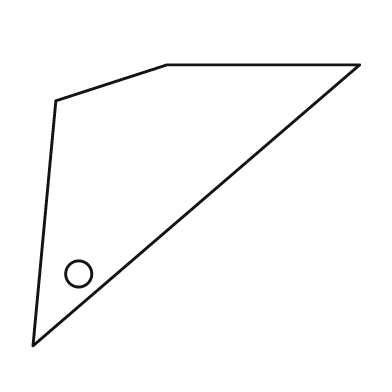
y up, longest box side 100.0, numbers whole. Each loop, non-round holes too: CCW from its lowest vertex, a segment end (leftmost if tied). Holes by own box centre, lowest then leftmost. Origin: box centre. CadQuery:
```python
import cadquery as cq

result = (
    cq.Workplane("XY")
    .moveTo(-50.0, -43.0)
    .lineTo(50.0, 43.0)
    .lineTo(-9.0, 43.0)
    .lineTo(-43.0, 32.0)
    .close()
    .moveTo(-36.0, -21.0)
    .circle(4.0)
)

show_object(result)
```